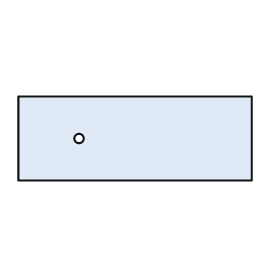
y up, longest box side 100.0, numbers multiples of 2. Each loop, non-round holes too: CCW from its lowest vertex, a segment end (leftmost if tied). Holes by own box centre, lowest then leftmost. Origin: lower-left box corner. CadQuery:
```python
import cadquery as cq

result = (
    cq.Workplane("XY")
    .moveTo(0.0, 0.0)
    .lineTo(100.0, 0.0)
    .lineTo(100.0, 36.0)
    .lineTo(0.0, 36.0)
    .close()
    .moveTo(26.0, 18.0)
    .circle(2.0)
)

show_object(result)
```